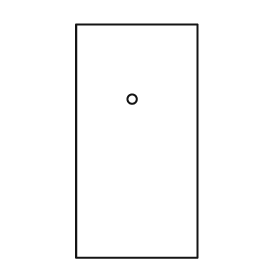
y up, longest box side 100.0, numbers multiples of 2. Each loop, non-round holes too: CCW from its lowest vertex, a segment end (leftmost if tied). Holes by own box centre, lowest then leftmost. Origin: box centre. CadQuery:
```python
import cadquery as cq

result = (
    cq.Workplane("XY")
    .moveTo(-26.0, -50.0)
    .lineTo(26.0, -50.0)
    .lineTo(26.0, 50.0)
    .lineTo(-26.0, 50.0)
    .close()
    .moveTo(-2.0, 18.0)
    .circle(2.0)
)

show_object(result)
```